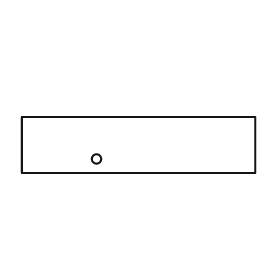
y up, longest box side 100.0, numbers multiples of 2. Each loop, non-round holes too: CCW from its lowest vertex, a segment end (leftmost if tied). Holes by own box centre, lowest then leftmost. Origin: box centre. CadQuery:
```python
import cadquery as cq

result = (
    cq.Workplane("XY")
    .moveTo(-50.0, -12.0)
    .lineTo(50.0, -12.0)
    .lineTo(50.0, 12.0)
    .lineTo(-50.0, 12.0)
    .close()
    .moveTo(-18.0, -6.0)
    .circle(2.0)
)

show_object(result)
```